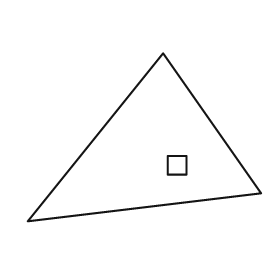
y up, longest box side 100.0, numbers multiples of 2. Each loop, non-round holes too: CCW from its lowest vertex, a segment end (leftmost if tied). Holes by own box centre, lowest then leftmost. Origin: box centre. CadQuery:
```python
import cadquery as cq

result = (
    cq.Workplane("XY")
    .moveTo(-50.0, -36.0)
    .lineTo(50.0, -24.0)
    .lineTo(8.0, 36.0)
    .close()
    .moveTo(10.0, -16.0)
    .lineTo(18.0, -16.0)
    .lineTo(18.0, -8.0)
    .lineTo(10.0, -8.0)
    .close()
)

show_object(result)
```